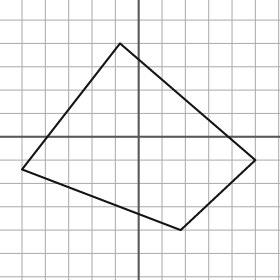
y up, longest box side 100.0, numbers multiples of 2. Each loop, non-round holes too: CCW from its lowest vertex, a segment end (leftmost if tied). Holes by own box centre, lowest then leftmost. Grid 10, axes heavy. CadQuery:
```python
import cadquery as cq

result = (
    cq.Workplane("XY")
    .moveTo(18.0, -40.0)
    .lineTo(50.0, -10.0)
    .lineTo(-8.0, 40.0)
    .lineTo(-50.0, -14.0)
    .close()
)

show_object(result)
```